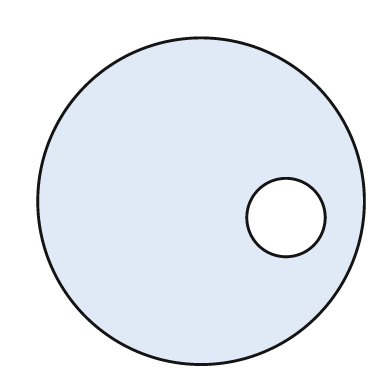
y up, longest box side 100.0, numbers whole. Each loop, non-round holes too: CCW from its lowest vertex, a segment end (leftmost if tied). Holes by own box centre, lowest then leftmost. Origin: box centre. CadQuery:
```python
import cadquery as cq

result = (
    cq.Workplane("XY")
    .moveTo(0.0, 0.0)
    .circle(50.0)
    .moveTo(26.0, -5.0)
    .circle(12.0)
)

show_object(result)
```